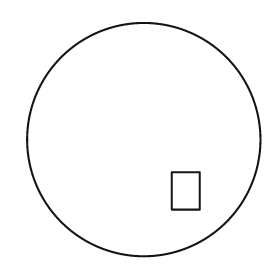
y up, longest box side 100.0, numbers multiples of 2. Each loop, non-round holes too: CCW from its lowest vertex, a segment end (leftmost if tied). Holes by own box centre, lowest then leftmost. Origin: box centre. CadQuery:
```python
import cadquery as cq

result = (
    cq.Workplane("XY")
    .moveTo(0.0, 0.0)
    .circle(50.0)
    .moveTo(12.0, -30.0)
    .lineTo(24.0, -30.0)
    .lineTo(24.0, -14.0)
    .lineTo(12.0, -14.0)
    .close()
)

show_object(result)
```